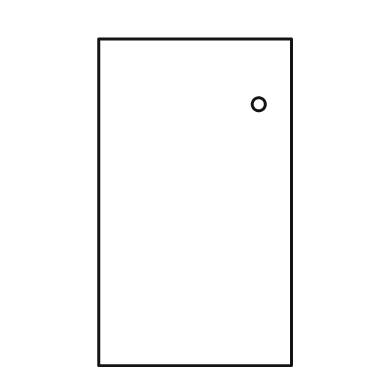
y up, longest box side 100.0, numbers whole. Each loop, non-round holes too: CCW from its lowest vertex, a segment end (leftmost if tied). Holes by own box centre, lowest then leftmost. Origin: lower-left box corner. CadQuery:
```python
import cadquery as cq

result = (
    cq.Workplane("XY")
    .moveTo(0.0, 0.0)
    .lineTo(59.0, 0.0)
    .lineTo(59.0, 100.0)
    .lineTo(0.0, 100.0)
    .close()
    .moveTo(49.0, 80.0)
    .circle(2.0)
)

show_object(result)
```